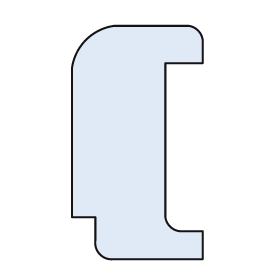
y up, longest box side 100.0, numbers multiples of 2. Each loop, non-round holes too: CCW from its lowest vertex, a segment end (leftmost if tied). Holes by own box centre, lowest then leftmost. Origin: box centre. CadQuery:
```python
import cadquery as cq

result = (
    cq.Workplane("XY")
    .moveTo(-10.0, -50.0)
    .lineTo(28.0, -50.0)
    .lineTo(28.0, -38.0)
    .lineTo(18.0, -38.0)
    .threePointArc((14.0, -36.0), (12.0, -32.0))
    .lineTo(12.0, 34.0)
    .lineTo(28.0, 34.0)
    .lineTo(28.0, 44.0)
    .threePointArc((26.0, 48.0), (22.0, 50.0))
    .lineTo(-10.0, 50.0)
    .threePointArc((-22.0, 44.0), (-28.0, 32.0))
    .lineTo(-28.0, -32.0)
    .lineTo(-18.0, -32.0)
    .lineTo(-18.0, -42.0)
    .threePointArc((-16.0, -48.0), (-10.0, -50.0))
    .close()
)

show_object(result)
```